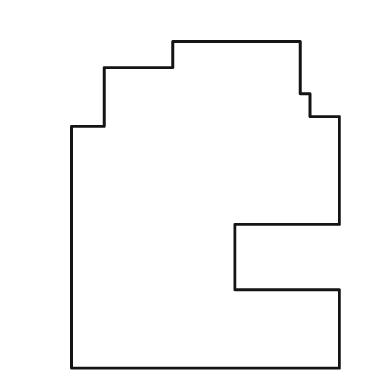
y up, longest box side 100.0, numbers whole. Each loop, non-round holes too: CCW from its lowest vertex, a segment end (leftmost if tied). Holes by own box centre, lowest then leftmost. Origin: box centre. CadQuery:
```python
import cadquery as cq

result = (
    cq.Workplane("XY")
    .moveTo(-41.0, -50.0)
    .lineTo(41.0, -50.0)
    .lineTo(41.0, -26.0)
    .lineTo(9.0, -26.0)
    .lineTo(9.0, -6.0)
    .lineTo(41.0, -6.0)
    .lineTo(41.0, 27.0)
    .lineTo(32.0, 27.0)
    .lineTo(32.0, 34.0)
    .lineTo(29.0, 34.0)
    .lineTo(29.0, 50.0)
    .lineTo(-10.0, 50.0)
    .lineTo(-10.0, 42.0)
    .lineTo(-31.0, 42.0)
    .lineTo(-31.0, 24.0)
    .lineTo(-41.0, 24.0)
    .close()
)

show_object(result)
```